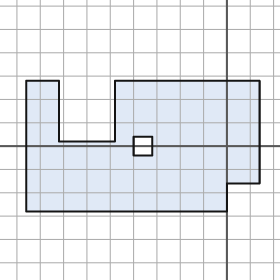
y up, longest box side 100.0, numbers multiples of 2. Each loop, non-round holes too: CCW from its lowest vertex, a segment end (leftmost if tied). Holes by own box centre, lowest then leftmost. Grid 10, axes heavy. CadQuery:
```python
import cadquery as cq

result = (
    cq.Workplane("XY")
    .moveTo(-86.0, -28.0)
    .lineTo(0.0, -28.0)
    .lineTo(0.0, -16.0)
    .lineTo(14.0, -16.0)
    .lineTo(14.0, 28.0)
    .lineTo(-48.0, 28.0)
    .lineTo(-48.0, 2.0)
    .lineTo(-72.0, 2.0)
    .lineTo(-72.0, 28.0)
    .lineTo(-86.0, 28.0)
    .close()
    .moveTo(-40.0, -4.0)
    .lineTo(-32.0, -4.0)
    .lineTo(-32.0, 4.0)
    .lineTo(-40.0, 4.0)
    .close()
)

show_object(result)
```